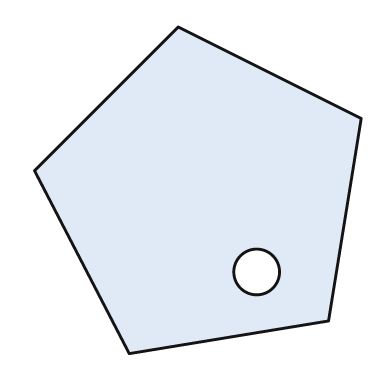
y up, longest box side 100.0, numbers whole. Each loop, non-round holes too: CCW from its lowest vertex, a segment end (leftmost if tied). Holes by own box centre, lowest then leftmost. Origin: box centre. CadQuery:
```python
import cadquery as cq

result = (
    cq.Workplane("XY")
    .moveTo(-21.0, -50.0)
    .lineTo(40.0, -40.0)
    .lineTo(50.0, 22.0)
    .lineTo(-6.0, 50.0)
    .lineTo(-50.0, 6.0)
    .close()
    .moveTo(18.0, -25.0)
    .circle(7.0)
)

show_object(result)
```